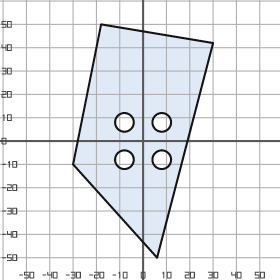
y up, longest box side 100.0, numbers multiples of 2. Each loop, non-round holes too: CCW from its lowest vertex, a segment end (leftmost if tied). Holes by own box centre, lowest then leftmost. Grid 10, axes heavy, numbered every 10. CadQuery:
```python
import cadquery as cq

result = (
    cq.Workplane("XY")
    .moveTo(6.0, -50.0)
    .lineTo(30.0, 42.0)
    .lineTo(-18.0, 50.0)
    .lineTo(-30.0, -10.0)
    .close()
    .moveTo(-8.0, -8.0)
    .circle(4.0)
    .moveTo(8.0, -8.0)
    .circle(4.0)
    .moveTo(-8.0, 8.0)
    .circle(4.0)
    .moveTo(8.0, 8.0)
    .circle(4.0)
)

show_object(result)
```